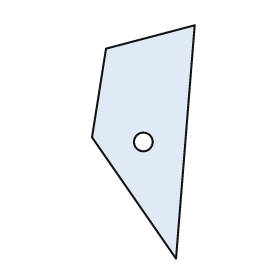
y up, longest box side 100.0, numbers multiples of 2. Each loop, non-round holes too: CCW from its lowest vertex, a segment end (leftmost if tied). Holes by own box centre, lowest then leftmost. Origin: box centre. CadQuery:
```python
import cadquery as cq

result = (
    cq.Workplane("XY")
    .moveTo(14.0, -50.0)
    .lineTo(22.0, 50.0)
    .lineTo(-16.0, 40.0)
    .lineTo(-22.0, 2.0)
    .close()
    .moveTo(0.0, 0.0)
    .circle(4.0)
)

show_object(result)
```